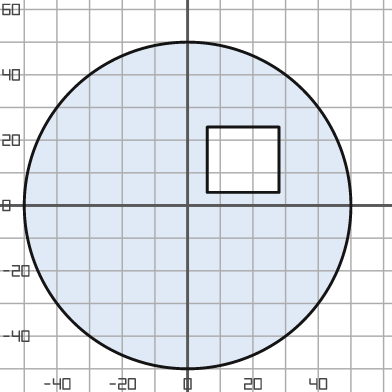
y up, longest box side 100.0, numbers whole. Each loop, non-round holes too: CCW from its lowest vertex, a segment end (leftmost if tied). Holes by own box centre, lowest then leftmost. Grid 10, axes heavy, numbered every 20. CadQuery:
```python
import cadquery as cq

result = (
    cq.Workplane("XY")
    .moveTo(0.0, 0.0)
    .circle(50.0)
    .moveTo(6.0, 4.0)
    .lineTo(28.0, 4.0)
    .lineTo(28.0, 24.0)
    .lineTo(6.0, 24.0)
    .close()
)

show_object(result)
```